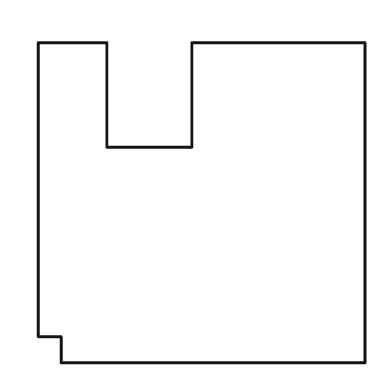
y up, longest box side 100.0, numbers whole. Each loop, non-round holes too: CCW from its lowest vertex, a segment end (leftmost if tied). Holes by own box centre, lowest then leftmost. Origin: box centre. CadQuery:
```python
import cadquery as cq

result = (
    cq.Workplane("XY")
    .moveTo(-43.0, -49.0)
    .lineTo(50.0, -49.0)
    .lineTo(50.0, 49.0)
    .lineTo(-3.0, 49.0)
    .lineTo(-3.0, 17.0)
    .lineTo(-29.0, 17.0)
    .lineTo(-29.0, 49.0)
    .lineTo(-50.0, 49.0)
    .lineTo(-50.0, -41.0)
    .lineTo(-43.0, -41.0)
    .close()
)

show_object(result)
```